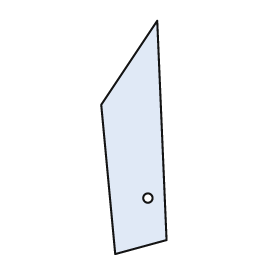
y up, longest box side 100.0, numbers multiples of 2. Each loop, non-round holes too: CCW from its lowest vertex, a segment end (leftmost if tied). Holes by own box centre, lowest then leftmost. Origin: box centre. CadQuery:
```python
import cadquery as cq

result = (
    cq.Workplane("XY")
    .moveTo(-8.0, -50.0)
    .lineTo(14.0, -44.0)
    .lineTo(10.0, 50.0)
    .lineTo(-14.0, 14.0)
    .close()
    .moveTo(6.0, -26.0)
    .circle(2.0)
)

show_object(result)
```